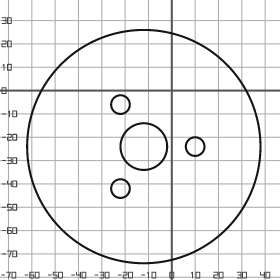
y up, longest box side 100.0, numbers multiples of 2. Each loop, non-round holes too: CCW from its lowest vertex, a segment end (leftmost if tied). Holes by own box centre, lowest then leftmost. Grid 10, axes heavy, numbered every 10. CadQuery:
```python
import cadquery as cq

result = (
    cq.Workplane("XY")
    .moveTo(-12.0, -24.0)
    .circle(50.0)
    .moveTo(-22.0, -42.0)
    .circle(4.0)
    .moveTo(-12.0, -24.0)
    .circle(10.0)
    .moveTo(10.0, -24.0)
    .circle(4.0)
    .moveTo(-22.0, -6.0)
    .circle(4.0)
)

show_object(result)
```